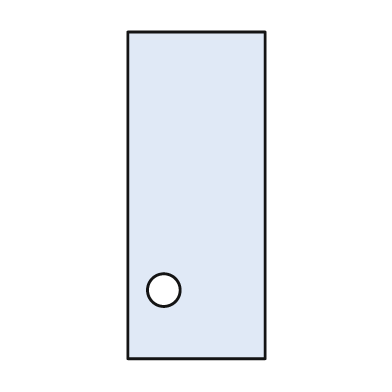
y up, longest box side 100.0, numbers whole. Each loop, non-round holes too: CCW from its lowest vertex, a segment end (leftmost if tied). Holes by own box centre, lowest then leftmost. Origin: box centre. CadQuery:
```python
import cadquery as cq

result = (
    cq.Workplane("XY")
    .moveTo(-21.0, -50.0)
    .lineTo(21.0, -50.0)
    .lineTo(21.0, 50.0)
    .lineTo(-21.0, 50.0)
    .close()
    .moveTo(-10.0, -29.0)
    .circle(5.0)
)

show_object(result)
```